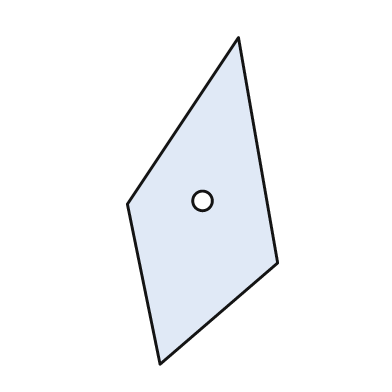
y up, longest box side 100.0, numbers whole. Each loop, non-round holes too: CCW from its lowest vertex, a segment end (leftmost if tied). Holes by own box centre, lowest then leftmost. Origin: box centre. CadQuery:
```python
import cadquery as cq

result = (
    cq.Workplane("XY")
    .moveTo(-13.0, -50.0)
    .lineTo(23.0, -19.0)
    .lineTo(11.0, 50.0)
    .lineTo(-23.0, -1.0)
    .close()
    .moveTo(0.0, 0.0)
    .circle(3.0)
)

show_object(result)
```